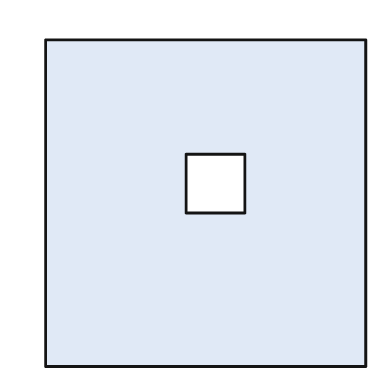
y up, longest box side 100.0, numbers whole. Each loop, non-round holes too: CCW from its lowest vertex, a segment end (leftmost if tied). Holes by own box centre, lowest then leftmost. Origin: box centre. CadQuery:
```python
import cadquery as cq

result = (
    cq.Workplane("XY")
    .moveTo(-49.0, -50.0)
    .lineTo(49.0, -50.0)
    .lineTo(49.0, 50.0)
    .lineTo(-49.0, 50.0)
    .close()
    .moveTo(-6.0, -3.0)
    .lineTo(12.0, -3.0)
    .lineTo(12.0, 15.0)
    .lineTo(-6.0, 15.0)
    .close()
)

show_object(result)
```